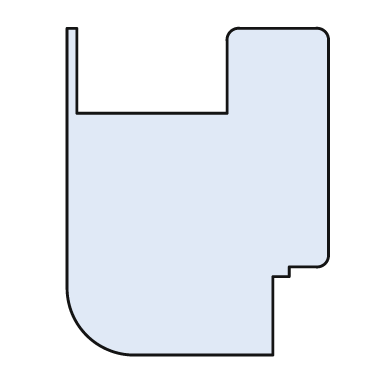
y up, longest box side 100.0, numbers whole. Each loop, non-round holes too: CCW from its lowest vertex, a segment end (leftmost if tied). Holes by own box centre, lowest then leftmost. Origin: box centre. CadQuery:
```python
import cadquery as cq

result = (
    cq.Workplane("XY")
    .moveTo(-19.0, -50.0)
    .lineTo(23.0, -50.0)
    .lineTo(23.0, -26.0)
    .lineTo(28.0, -26.0)
    .lineTo(28.0, -23.0)
    .lineTo(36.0, -23.0)
    .threePointArc((39.0, -22.0), (40.0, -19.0))
    .lineTo(40.0, 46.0)
    .threePointArc((39.0, 49.0), (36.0, 50.0))
    .lineTo(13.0, 50.0)
    .threePointArc((10.0, 49.0), (9.0, 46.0))
    .lineTo(9.0, 24.0)
    .lineTo(-37.0, 24.0)
    .lineTo(-37.0, 50.0)
    .lineTo(-40.0, 50.0)
    .lineTo(-40.0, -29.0)
    .threePointArc((-34.0, -44.0), (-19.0, -50.0))
    .close()
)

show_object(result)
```